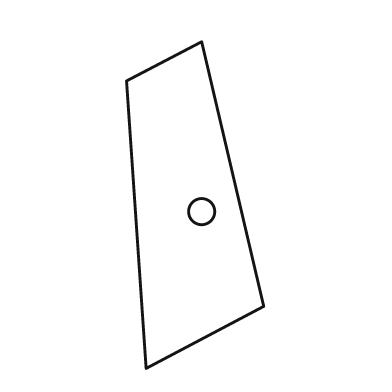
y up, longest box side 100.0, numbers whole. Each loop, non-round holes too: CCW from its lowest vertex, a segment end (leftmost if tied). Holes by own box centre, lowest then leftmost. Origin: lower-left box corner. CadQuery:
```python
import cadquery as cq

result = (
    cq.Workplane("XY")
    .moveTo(6.0, 0.0)
    .lineTo(42.0, 19.0)
    .lineTo(23.0, 100.0)
    .lineTo(0.0, 88.0)
    .close()
    .moveTo(23.0, 48.0)
    .circle(4.0)
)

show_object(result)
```